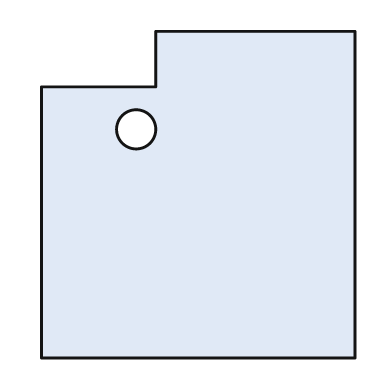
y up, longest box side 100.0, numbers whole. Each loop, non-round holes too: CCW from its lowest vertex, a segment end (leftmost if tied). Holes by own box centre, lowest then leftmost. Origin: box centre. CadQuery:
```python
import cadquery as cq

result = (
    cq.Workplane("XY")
    .moveTo(-48.0, -50.0)
    .lineTo(48.0, -50.0)
    .lineTo(48.0, 50.0)
    .lineTo(-13.0, 50.0)
    .lineTo(-13.0, 33.0)
    .lineTo(-48.0, 33.0)
    .close()
    .moveTo(-19.0, 20.0)
    .circle(6.0)
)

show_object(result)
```